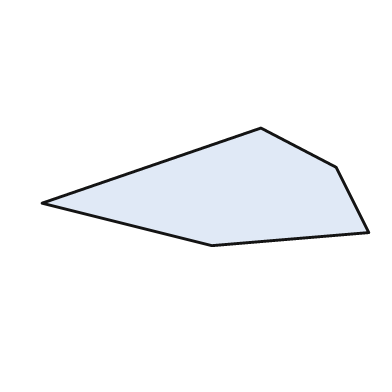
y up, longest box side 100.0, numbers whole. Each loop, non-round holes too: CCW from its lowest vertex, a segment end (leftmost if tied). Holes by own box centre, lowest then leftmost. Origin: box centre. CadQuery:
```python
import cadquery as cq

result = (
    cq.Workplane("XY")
    .moveTo(2.0, -18.0)
    .lineTo(50.0, -14.0)
    .lineTo(40.0, 6.0)
    .lineTo(17.0, 18.0)
    .lineTo(-50.0, -5.0)
    .close()
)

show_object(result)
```